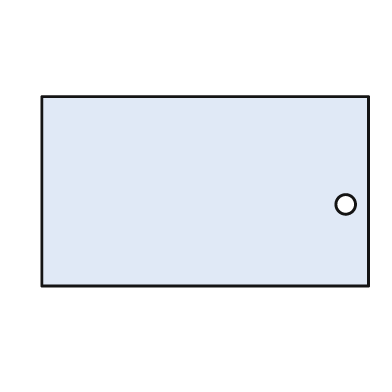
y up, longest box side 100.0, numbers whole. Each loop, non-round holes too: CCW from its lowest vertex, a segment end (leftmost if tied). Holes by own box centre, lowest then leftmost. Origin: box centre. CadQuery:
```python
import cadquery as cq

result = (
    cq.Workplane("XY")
    .moveTo(-50.0, -29.0)
    .lineTo(50.0, -29.0)
    .lineTo(50.0, 29.0)
    .lineTo(-50.0, 29.0)
    .close()
    .moveTo(43.0, -4.0)
    .circle(3.0)
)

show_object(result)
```